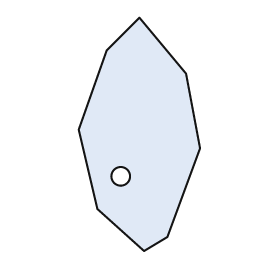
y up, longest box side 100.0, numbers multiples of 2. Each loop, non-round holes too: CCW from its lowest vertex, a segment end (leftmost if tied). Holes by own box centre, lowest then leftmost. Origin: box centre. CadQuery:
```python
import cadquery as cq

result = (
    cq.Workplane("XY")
    .moveTo(2.0, -50.0)
    .lineTo(12.0, -44.0)
    .lineTo(26.0, -6.0)
    .lineTo(20.0, 26.0)
    .lineTo(0.0, 50.0)
    .lineTo(-14.0, 36.0)
    .lineTo(-26.0, 2.0)
    .lineTo(-18.0, -32.0)
    .close()
    .moveTo(-8.0, -18.0)
    .circle(4.0)
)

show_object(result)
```